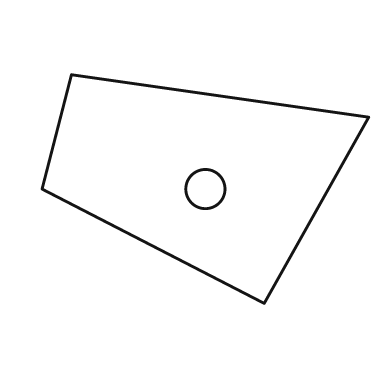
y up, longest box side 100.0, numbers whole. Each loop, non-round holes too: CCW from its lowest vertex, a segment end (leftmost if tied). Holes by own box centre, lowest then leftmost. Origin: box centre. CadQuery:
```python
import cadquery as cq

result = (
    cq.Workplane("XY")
    .moveTo(18.0, -35.0)
    .lineTo(50.0, 22.0)
    .lineTo(-41.0, 35.0)
    .lineTo(-50.0, 0.0)
    .close()
    .moveTo(0.0, 0.0)
    .circle(6.0)
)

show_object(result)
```